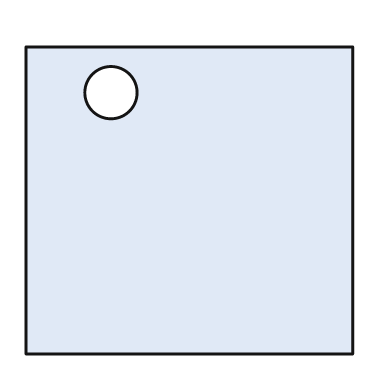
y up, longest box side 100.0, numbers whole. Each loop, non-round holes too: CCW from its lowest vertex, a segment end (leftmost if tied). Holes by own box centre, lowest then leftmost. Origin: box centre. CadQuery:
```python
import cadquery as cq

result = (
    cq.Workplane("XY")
    .moveTo(-50.0, -47.0)
    .lineTo(50.0, -47.0)
    .lineTo(50.0, 47.0)
    .lineTo(-50.0, 47.0)
    .close()
    .moveTo(-24.0, 33.0)
    .circle(8.0)
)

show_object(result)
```